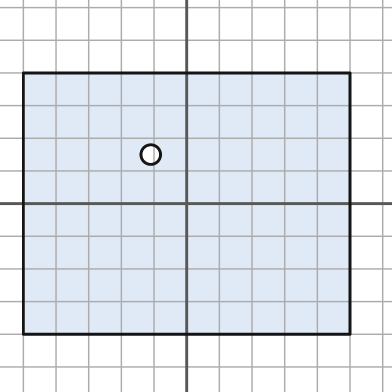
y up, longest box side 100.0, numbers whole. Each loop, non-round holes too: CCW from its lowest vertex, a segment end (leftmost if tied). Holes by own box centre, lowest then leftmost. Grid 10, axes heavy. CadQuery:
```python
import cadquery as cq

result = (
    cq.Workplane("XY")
    .moveTo(-50.0, -40.0)
    .lineTo(50.0, -40.0)
    .lineTo(50.0, 40.0)
    .lineTo(-50.0, 40.0)
    .close()
    .moveTo(-11.0, 15.0)
    .circle(3.0)
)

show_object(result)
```